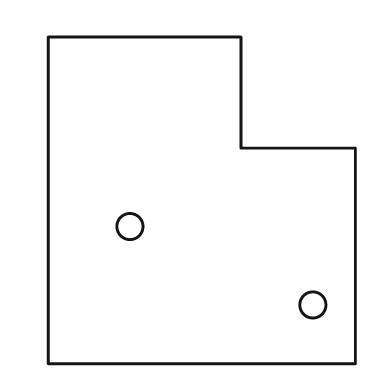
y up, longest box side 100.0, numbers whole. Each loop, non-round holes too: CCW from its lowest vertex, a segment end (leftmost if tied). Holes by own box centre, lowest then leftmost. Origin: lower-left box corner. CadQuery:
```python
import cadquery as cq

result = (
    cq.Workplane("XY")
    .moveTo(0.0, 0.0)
    .lineTo(94.0, 0.0)
    .lineTo(94.0, 66.0)
    .lineTo(59.0, 66.0)
    .lineTo(59.0, 100.0)
    .lineTo(0.0, 100.0)
    .close()
    .moveTo(81.0, 18.0)
    .circle(4.0)
    .moveTo(25.0, 42.0)
    .circle(4.0)
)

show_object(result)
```